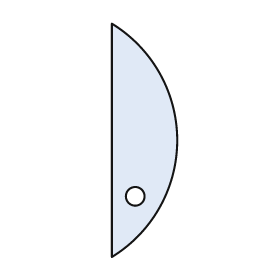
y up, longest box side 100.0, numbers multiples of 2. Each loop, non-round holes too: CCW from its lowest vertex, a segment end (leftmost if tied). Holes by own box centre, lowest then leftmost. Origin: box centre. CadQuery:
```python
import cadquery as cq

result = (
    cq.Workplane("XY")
    .moveTo(-14.0, -50.0)
    .threePointArc((14.0, 0.0), (-14.0, 50.0))
    .close()
    .moveTo(-4.0, -24.0)
    .circle(4.0)
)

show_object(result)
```